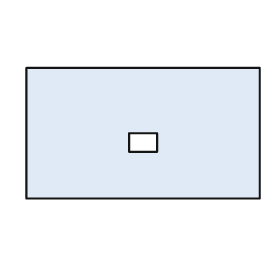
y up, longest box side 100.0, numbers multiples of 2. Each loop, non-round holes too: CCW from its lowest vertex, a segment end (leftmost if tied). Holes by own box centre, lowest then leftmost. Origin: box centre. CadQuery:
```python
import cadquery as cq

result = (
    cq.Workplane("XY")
    .moveTo(-50.0, -28.0)
    .lineTo(50.0, -28.0)
    .lineTo(50.0, 28.0)
    .lineTo(-50.0, 28.0)
    .close()
    .moveTo(-6.0, -8.0)
    .lineTo(6.0, -8.0)
    .lineTo(6.0, 0.0)
    .lineTo(-6.0, 0.0)
    .close()
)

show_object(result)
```